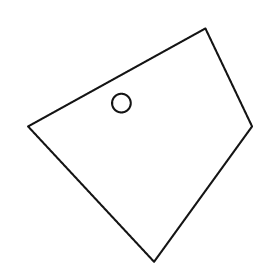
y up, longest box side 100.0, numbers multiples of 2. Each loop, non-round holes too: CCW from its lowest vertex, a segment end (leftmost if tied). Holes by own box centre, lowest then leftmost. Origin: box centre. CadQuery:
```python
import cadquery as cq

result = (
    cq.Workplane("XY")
    .moveTo(6.0, -50.0)
    .lineTo(48.0, 8.0)
    .lineTo(28.0, 50.0)
    .lineTo(-48.0, 8.0)
    .close()
    .moveTo(-8.0, 18.0)
    .circle(4.0)
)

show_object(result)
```